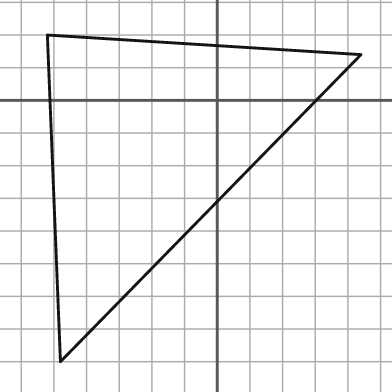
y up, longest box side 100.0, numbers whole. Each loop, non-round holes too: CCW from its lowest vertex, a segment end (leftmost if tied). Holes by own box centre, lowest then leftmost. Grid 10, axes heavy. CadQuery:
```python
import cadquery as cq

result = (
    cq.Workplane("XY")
    .moveTo(-48.0, -80.0)
    .lineTo(44.0, 14.0)
    .lineTo(-52.0, 20.0)
    .close()
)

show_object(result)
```